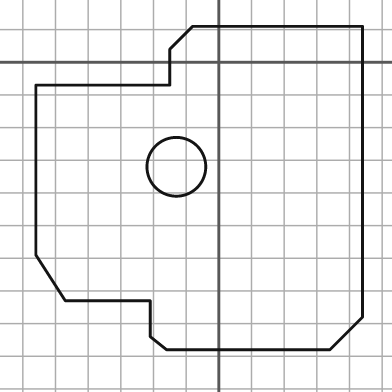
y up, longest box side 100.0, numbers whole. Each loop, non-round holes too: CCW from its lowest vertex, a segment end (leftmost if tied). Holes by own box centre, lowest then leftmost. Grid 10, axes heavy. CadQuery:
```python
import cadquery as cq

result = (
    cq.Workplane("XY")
    .moveTo(-16.0, -88.0)
    .lineTo(34.0, -88.0)
    .lineTo(44.0, -78.0)
    .lineTo(44.0, 11.0)
    .lineTo(-8.0, 11.0)
    .lineTo(-15.0, 4.0)
    .lineTo(-15.0, -7.0)
    .lineTo(-56.0, -7.0)
    .lineTo(-56.0, -59.0)
    .lineTo(-47.0, -73.0)
    .lineTo(-21.0, -73.0)
    .lineTo(-21.0, -84.0)
    .close()
    .moveTo(-13.0, -32.0)
    .circle(9.0)
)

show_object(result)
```